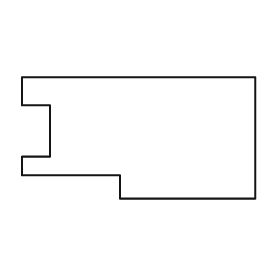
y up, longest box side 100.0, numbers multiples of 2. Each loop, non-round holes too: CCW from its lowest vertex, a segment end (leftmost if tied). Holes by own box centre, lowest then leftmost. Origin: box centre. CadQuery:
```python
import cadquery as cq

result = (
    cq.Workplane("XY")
    .moveTo(-8.0, -26.0)
    .lineTo(50.0, -26.0)
    .lineTo(50.0, 26.0)
    .lineTo(-50.0, 26.0)
    .lineTo(-50.0, 14.0)
    .lineTo(-38.0, 14.0)
    .lineTo(-38.0, -8.0)
    .lineTo(-50.0, -8.0)
    .lineTo(-50.0, -16.0)
    .lineTo(-8.0, -16.0)
    .close()
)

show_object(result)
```